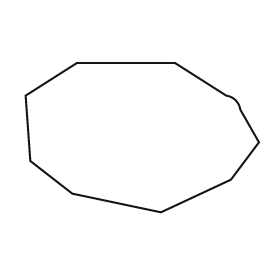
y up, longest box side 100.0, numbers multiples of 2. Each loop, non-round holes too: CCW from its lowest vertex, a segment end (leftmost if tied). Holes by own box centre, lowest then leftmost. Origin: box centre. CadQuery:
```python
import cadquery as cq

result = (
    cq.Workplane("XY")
    .moveTo(8.0, -32.0)
    .lineTo(38.0, -18.0)
    .lineTo(50.0, -2.0)
    .lineTo(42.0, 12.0)
    .threePointArc((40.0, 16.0), (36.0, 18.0))
    .lineTo(14.0, 32.0)
    .lineTo(-28.0, 32.0)
    .lineTo(-50.0, 18.0)
    .lineTo(-48.0, -10.0)
    .lineTo(-30.0, -24.0)
    .close()
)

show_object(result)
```